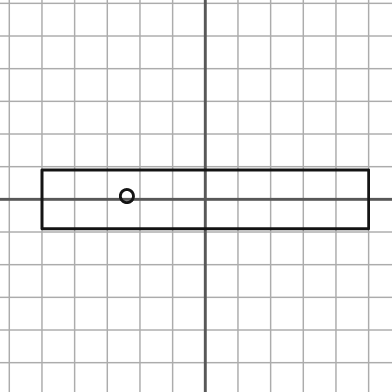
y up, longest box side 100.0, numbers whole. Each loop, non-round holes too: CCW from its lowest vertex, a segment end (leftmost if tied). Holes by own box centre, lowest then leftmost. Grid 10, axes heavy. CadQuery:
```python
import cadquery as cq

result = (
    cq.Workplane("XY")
    .moveTo(-50.0, -9.0)
    .lineTo(50.0, -9.0)
    .lineTo(50.0, 9.0)
    .lineTo(-50.0, 9.0)
    .close()
    .moveTo(-24.0, 1.0)
    .circle(2.0)
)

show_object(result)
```